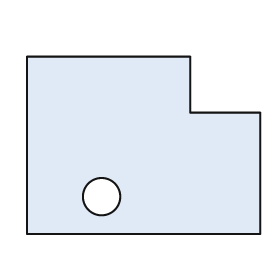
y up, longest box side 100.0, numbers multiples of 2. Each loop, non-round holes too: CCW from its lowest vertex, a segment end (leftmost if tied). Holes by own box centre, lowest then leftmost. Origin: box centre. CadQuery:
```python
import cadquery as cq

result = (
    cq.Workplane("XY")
    .moveTo(-50.0, -38.0)
    .lineTo(50.0, -38.0)
    .lineTo(50.0, 14.0)
    .lineTo(20.0, 14.0)
    .lineTo(20.0, 38.0)
    .lineTo(-50.0, 38.0)
    .close()
    .moveTo(-18.0, -22.0)
    .circle(8.0)
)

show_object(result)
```